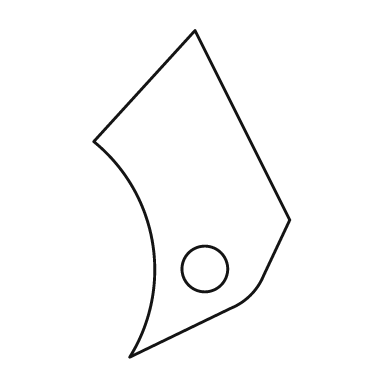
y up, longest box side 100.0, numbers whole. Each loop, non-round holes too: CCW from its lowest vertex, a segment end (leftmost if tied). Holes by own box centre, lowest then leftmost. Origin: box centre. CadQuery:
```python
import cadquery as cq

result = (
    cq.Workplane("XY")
    .moveTo(-19.0, -50.0)
    .lineTo(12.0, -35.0)
    .threePointArc((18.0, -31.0), (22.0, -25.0))
    .lineTo(30.0, -8.0)
    .lineTo(1.0, 50.0)
    .lineTo(-30.0, 16.0)
    .threePointArc((-12.0, -15.0), (-19.0, -50.0))
    .close()
    .moveTo(4.0, -23.0)
    .circle(7.0)
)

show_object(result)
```